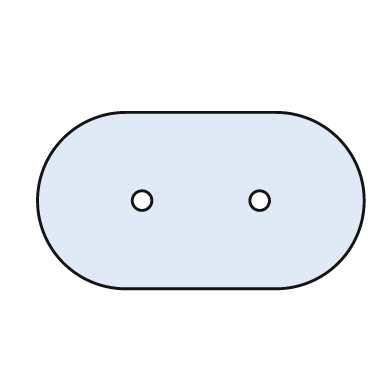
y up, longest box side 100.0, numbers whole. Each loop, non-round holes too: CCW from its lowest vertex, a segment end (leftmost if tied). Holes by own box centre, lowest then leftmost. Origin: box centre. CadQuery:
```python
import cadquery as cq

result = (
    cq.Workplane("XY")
    .moveTo(-23.0, -27.0)
    .lineTo(23.0, -27.0)
    .threePointArc((50.0, 0.0), (23.0, 27.0))
    .lineTo(-23.0, 27.0)
    .threePointArc((-50.0, 0.0), (-23.0, -27.0))
    .close()
    .moveTo(-18.0, 0.0)
    .circle(3.0)
    .moveTo(18.0, 0.0)
    .circle(3.0)
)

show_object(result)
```